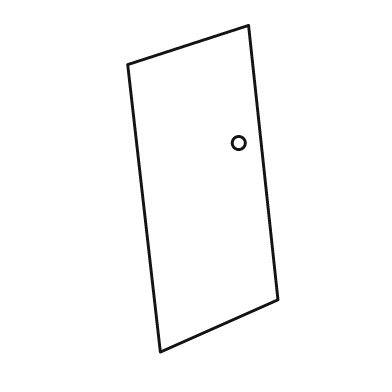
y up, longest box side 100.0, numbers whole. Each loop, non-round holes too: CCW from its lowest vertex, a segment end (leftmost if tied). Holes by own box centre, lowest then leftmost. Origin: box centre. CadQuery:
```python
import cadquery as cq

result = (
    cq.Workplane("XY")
    .moveTo(-13.0, -50.0)
    .lineTo(23.0, -34.0)
    .lineTo(14.0, 50.0)
    .lineTo(-23.0, 38.0)
    .close()
    .moveTo(11.0, 14.0)
    .circle(2.0)
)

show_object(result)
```